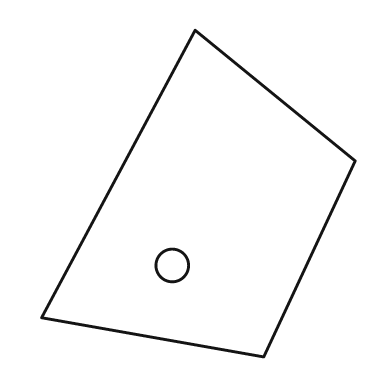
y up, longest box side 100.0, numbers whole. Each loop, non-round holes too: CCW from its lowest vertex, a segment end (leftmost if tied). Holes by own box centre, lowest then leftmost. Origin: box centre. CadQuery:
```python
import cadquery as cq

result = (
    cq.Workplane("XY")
    .moveTo(20.0, -50.0)
    .lineTo(48.0, 10.0)
    .lineTo(-1.0, 50.0)
    .lineTo(-48.0, -38.0)
    .close()
    .moveTo(-8.0, -22.0)
    .circle(5.0)
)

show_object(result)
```